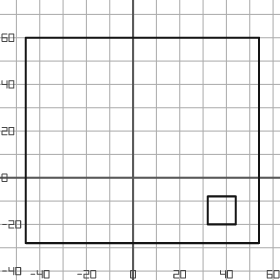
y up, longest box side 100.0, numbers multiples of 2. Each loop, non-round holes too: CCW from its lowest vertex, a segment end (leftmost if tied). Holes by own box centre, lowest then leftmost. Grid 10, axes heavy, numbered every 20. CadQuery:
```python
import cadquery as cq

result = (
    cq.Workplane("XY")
    .moveTo(-46.0, -28.0)
    .lineTo(54.0, -28.0)
    .lineTo(54.0, 60.0)
    .lineTo(-46.0, 60.0)
    .close()
    .moveTo(32.0, -20.0)
    .lineTo(44.0, -20.0)
    .lineTo(44.0, -8.0)
    .lineTo(32.0, -8.0)
    .close()
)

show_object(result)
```